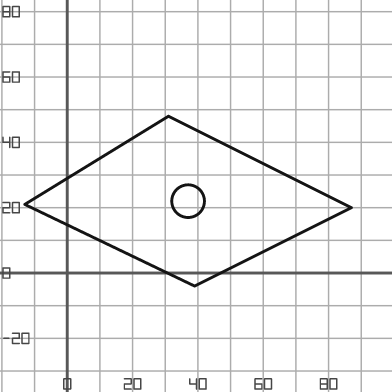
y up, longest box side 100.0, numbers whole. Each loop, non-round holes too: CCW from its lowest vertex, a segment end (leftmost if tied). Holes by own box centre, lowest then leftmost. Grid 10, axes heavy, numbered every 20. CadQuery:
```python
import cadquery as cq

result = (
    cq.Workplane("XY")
    .moveTo(39.0, -4.0)
    .lineTo(87.0, 20.0)
    .lineTo(31.0, 48.0)
    .lineTo(-13.0, 21.0)
    .close()
    .moveTo(37.0, 22.0)
    .circle(5.0)
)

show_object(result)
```